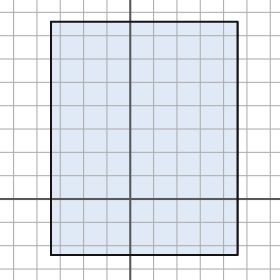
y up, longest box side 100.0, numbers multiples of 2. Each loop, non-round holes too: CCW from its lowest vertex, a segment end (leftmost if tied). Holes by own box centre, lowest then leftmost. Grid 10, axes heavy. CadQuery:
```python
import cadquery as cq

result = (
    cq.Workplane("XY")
    .moveTo(-34.0, -24.0)
    .lineTo(46.0, -24.0)
    .lineTo(46.0, 76.0)
    .lineTo(-34.0, 76.0)
    .close()
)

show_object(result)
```